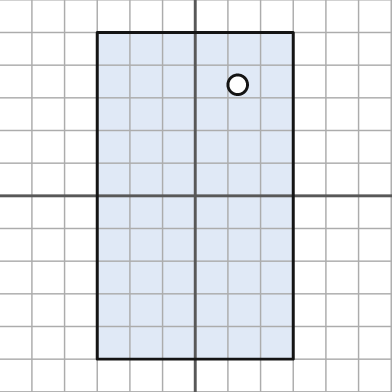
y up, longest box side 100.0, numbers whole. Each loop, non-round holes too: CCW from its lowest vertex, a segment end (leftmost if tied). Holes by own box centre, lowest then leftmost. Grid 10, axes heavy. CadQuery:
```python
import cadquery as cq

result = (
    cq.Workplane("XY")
    .moveTo(-30.0, -50.0)
    .lineTo(30.0, -50.0)
    .lineTo(30.0, 50.0)
    .lineTo(-30.0, 50.0)
    .close()
    .moveTo(13.0, 34.0)
    .circle(3.0)
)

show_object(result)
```